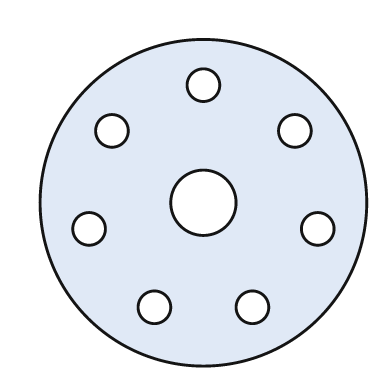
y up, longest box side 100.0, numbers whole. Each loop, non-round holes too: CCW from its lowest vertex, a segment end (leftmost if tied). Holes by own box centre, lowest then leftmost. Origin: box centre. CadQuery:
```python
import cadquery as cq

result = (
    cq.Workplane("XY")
    .moveTo(0.0, 0.0)
    .circle(50.0)
    .moveTo(-15.0, -32.0)
    .circle(5.0)
    .moveTo(15.0, -32.0)
    .circle(5.0)
    .moveTo(-35.0, -8.0)
    .circle(5.0)
    .moveTo(35.0, -8.0)
    .circle(5.0)
    .moveTo(0.0, 0.0)
    .circle(10.0)
    .moveTo(-28.0, 22.0)
    .circle(5.0)
    .moveTo(28.0, 22.0)
    .circle(5.0)
    .moveTo(0.0, 36.0)
    .circle(5.0)
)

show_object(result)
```